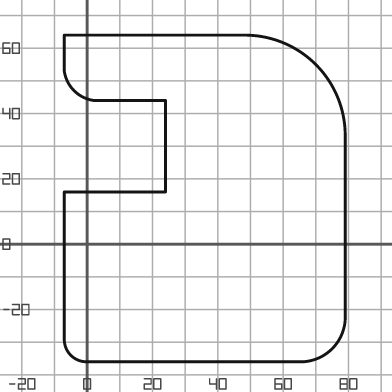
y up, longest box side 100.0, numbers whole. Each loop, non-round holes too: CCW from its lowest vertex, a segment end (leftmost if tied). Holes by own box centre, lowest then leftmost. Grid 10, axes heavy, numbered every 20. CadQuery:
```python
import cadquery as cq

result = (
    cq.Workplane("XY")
    .moveTo(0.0, -36.0)
    .lineTo(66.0, -36.0)
    .threePointArc((75.0, -32.0), (79.0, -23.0))
    .lineTo(79.0, 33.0)
    .threePointArc((70.0, 55.0), (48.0, 64.0))
    .lineTo(-7.0, 64.0)
    .lineTo(-7.0, 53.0)
    .threePointArc((-4.0, 47.0), (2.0, 44.0))
    .lineTo(24.0, 44.0)
    .lineTo(24.0, 16.0)
    .lineTo(-7.0, 16.0)
    .lineTo(-7.0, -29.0)
    .threePointArc((-5.0, -34.0), (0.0, -36.0))
    .close()
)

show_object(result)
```